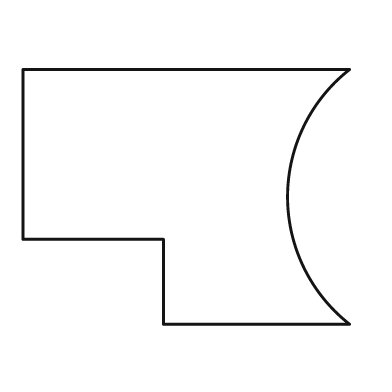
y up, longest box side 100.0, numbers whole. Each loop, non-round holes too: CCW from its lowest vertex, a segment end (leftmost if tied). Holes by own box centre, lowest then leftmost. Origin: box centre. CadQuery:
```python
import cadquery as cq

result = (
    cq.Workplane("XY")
    .moveTo(-7.0, -39.0)
    .lineTo(50.0, -39.0)
    .threePointArc((31.0, 0.0), (50.0, 39.0))
    .lineTo(-50.0, 39.0)
    .lineTo(-50.0, -13.0)
    .lineTo(-7.0, -13.0)
    .close()
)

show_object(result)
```